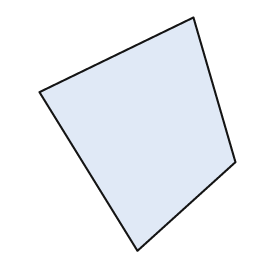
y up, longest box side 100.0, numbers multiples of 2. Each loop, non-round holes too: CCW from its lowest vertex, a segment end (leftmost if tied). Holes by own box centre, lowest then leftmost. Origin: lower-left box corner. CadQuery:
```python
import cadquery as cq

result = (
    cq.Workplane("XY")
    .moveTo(42.0, 0.0)
    .lineTo(84.0, 38.0)
    .lineTo(66.0, 100.0)
    .lineTo(0.0, 68.0)
    .close()
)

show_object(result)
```